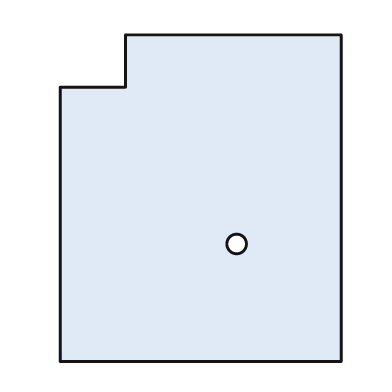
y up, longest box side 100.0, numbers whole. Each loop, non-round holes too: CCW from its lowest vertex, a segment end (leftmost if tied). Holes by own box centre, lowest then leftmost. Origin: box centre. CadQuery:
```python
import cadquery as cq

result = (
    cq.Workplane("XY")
    .moveTo(-43.0, -50.0)
    .lineTo(43.0, -50.0)
    .lineTo(43.0, 50.0)
    .lineTo(-23.0, 50.0)
    .lineTo(-23.0, 34.0)
    .lineTo(-43.0, 34.0)
    .close()
    .moveTo(11.0, -14.0)
    .circle(3.0)
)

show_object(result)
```